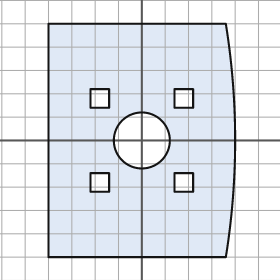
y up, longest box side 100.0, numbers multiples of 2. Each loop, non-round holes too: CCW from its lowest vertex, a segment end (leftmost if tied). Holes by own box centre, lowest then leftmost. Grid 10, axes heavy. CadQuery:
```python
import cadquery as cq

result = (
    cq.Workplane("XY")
    .moveTo(-40.0, -50.0)
    .lineTo(36.0, -50.0)
    .threePointArc((40.0, 0.0), (36.0, 50.0))
    .lineTo(-40.0, 50.0)
    .close()
    .moveTo(-22.0, -22.0)
    .lineTo(-14.0, -22.0)
    .lineTo(-14.0, -14.0)
    .lineTo(-22.0, -14.0)
    .close()
    .moveTo(14.0, -22.0)
    .lineTo(22.0, -22.0)
    .lineTo(22.0, -14.0)
    .lineTo(14.0, -14.0)
    .close()
    .moveTo(0.0, 0.0)
    .circle(12.0)
    .moveTo(-22.0, 14.0)
    .lineTo(-14.0, 14.0)
    .lineTo(-14.0, 22.0)
    .lineTo(-22.0, 22.0)
    .close()
    .moveTo(14.0, 14.0)
    .lineTo(22.0, 14.0)
    .lineTo(22.0, 22.0)
    .lineTo(14.0, 22.0)
    .close()
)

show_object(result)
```